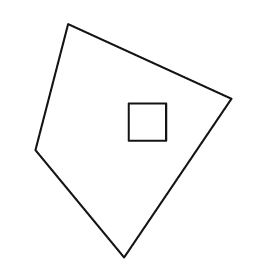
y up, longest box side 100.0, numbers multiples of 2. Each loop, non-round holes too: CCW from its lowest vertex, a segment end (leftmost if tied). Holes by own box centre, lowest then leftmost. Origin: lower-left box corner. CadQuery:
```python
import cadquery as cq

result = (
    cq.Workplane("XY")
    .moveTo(38.0, 0.0)
    .lineTo(84.0, 68.0)
    .lineTo(14.0, 100.0)
    .lineTo(0.0, 46.0)
    .close()
    .moveTo(40.0, 50.0)
    .lineTo(56.0, 50.0)
    .lineTo(56.0, 66.0)
    .lineTo(40.0, 66.0)
    .close()
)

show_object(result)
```